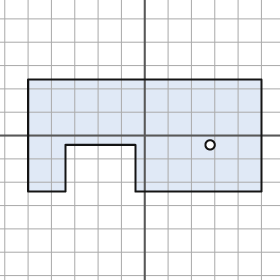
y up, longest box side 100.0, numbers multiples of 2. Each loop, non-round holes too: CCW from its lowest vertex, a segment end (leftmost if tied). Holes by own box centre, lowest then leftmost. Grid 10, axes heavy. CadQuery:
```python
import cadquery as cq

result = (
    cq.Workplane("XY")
    .moveTo(-50.0, -24.0)
    .lineTo(-34.0, -24.0)
    .lineTo(-34.0, -4.0)
    .lineTo(-4.0, -4.0)
    .lineTo(-4.0, -24.0)
    .lineTo(50.0, -24.0)
    .lineTo(50.0, 24.0)
    .lineTo(-50.0, 24.0)
    .close()
    .moveTo(28.0, -4.0)
    .circle(2.0)
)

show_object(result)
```